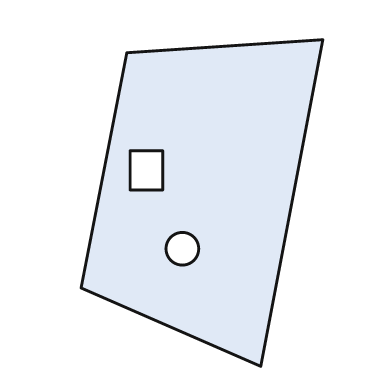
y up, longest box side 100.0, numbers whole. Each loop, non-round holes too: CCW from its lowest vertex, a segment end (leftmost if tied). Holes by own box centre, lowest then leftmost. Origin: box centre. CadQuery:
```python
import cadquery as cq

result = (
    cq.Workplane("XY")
    .moveTo(18.0, -50.0)
    .lineTo(37.0, 50.0)
    .lineTo(-23.0, 46.0)
    .lineTo(-37.0, -26.0)
    .close()
    .moveTo(-6.0, -14.0)
    .circle(5.0)
    .moveTo(-22.0, 4.0)
    .lineTo(-12.0, 4.0)
    .lineTo(-12.0, 16.0)
    .lineTo(-22.0, 16.0)
    .close()
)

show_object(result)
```